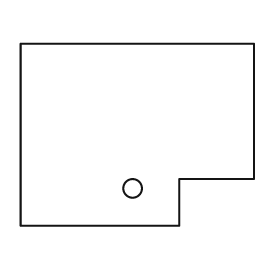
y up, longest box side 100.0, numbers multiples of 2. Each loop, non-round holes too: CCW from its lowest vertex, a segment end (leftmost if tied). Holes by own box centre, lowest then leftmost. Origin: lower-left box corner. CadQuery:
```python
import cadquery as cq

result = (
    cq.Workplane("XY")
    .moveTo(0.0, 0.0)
    .lineTo(68.0, 0.0)
    .lineTo(68.0, 20.0)
    .lineTo(100.0, 20.0)
    .lineTo(100.0, 78.0)
    .lineTo(0.0, 78.0)
    .close()
    .moveTo(48.0, 16.0)
    .circle(4.0)
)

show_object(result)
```